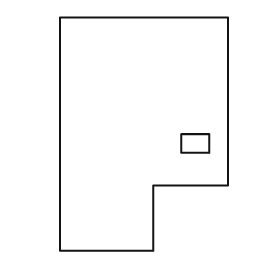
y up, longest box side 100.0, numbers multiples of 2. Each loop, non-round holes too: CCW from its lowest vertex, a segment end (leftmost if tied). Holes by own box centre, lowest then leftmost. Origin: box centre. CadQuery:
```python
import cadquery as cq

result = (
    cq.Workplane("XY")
    .moveTo(-36.0, -50.0)
    .lineTo(4.0, -50.0)
    .lineTo(4.0, -22.0)
    .lineTo(36.0, -22.0)
    .lineTo(36.0, 50.0)
    .lineTo(-36.0, 50.0)
    .close()
    .moveTo(16.0, -8.0)
    .lineTo(28.0, -8.0)
    .lineTo(28.0, 0.0)
    .lineTo(16.0, 0.0)
    .close()
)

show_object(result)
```